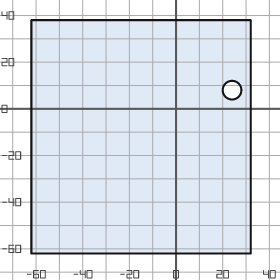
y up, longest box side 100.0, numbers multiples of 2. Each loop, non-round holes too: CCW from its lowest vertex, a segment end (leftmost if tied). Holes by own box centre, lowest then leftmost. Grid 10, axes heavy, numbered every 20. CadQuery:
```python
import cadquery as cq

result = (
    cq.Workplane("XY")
    .moveTo(-62.0, -62.0)
    .lineTo(32.0, -62.0)
    .lineTo(32.0, 38.0)
    .lineTo(-62.0, 38.0)
    .close()
    .moveTo(24.0, 8.0)
    .circle(4.0)
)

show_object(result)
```